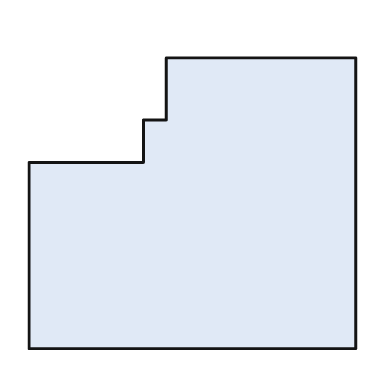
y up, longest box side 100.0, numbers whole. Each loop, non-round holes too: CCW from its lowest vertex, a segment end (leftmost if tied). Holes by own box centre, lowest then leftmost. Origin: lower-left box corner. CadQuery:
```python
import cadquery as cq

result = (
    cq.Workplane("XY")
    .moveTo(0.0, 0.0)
    .lineTo(100.0, 0.0)
    .lineTo(100.0, 89.0)
    .lineTo(42.0, 89.0)
    .lineTo(42.0, 70.0)
    .lineTo(35.0, 70.0)
    .lineTo(35.0, 57.0)
    .lineTo(0.0, 57.0)
    .close()
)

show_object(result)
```